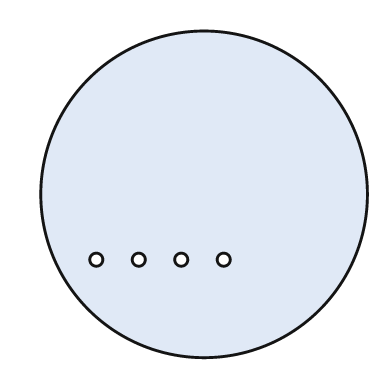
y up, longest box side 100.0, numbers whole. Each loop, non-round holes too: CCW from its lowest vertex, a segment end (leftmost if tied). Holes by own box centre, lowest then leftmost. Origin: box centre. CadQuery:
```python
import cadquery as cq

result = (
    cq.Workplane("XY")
    .moveTo(0.0, 0.0)
    .circle(50.0)
    .moveTo(-33.0, -20.0)
    .circle(2.0)
    .moveTo(-20.0, -20.0)
    .circle(2.0)
    .moveTo(-7.0, -20.0)
    .circle(2.0)
    .moveTo(6.0, -20.0)
    .circle(2.0)
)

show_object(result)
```